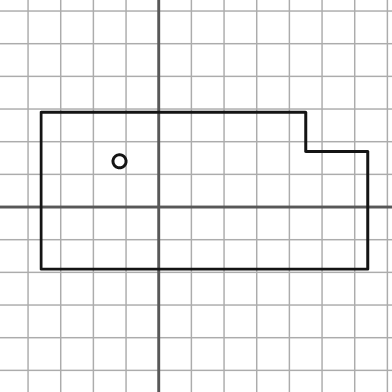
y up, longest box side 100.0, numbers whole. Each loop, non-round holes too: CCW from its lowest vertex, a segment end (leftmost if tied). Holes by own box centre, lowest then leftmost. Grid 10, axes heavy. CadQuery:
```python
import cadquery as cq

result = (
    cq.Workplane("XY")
    .moveTo(-36.0, -19.0)
    .lineTo(64.0, -19.0)
    .lineTo(64.0, 17.0)
    .lineTo(45.0, 17.0)
    .lineTo(45.0, 29.0)
    .lineTo(-36.0, 29.0)
    .close()
    .moveTo(-12.0, 14.0)
    .circle(2.0)
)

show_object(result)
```